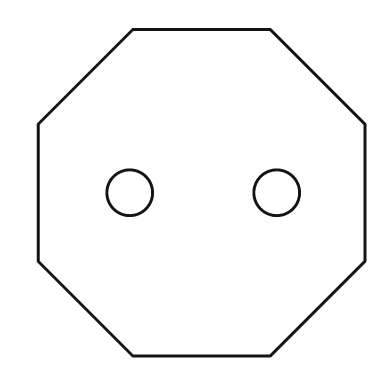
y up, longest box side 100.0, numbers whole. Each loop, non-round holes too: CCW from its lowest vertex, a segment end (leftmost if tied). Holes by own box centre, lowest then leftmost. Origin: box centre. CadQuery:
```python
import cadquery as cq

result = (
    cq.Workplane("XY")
    .moveTo(-21.0, -50.0)
    .lineTo(21.0, -50.0)
    .lineTo(50.0, -21.0)
    .lineTo(50.0, 21.0)
    .lineTo(21.0, 50.0)
    .lineTo(-21.0, 50.0)
    .lineTo(-50.0, 21.0)
    .lineTo(-50.0, -21.0)
    .close()
    .moveTo(-22.0, 0.0)
    .circle(7.0)
    .moveTo(23.0, 0.0)
    .circle(7.0)
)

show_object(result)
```